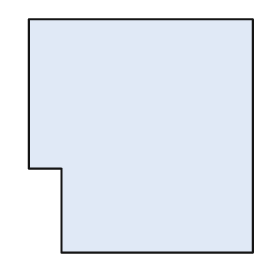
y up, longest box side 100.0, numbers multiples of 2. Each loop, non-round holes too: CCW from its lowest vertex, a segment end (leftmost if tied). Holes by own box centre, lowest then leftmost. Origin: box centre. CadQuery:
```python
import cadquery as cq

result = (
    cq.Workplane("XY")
    .moveTo(-34.0, -50.0)
    .lineTo(48.0, -50.0)
    .lineTo(48.0, 50.0)
    .lineTo(-48.0, 50.0)
    .lineTo(-48.0, -14.0)
    .lineTo(-34.0, -14.0)
    .close()
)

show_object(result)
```